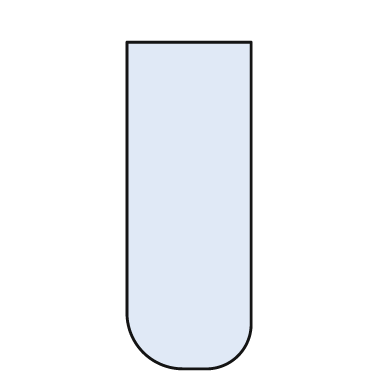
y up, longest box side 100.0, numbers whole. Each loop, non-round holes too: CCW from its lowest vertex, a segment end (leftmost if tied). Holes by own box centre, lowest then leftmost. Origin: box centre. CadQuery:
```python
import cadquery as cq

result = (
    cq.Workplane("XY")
    .moveTo(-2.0, -50.0)
    .lineTo(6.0, -50.0)
    .threePointArc((15.0, -46.0), (19.0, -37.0))
    .lineTo(19.0, 50.0)
    .lineTo(-19.0, 50.0)
    .lineTo(-19.0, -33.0)
    .threePointArc((-14.0, -45.0), (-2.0, -50.0))
    .close()
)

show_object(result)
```